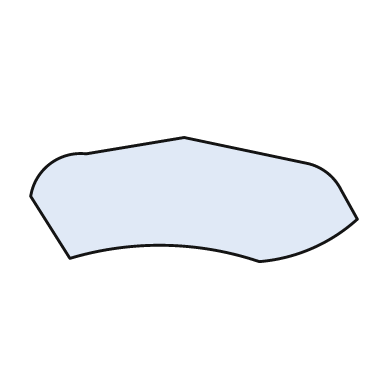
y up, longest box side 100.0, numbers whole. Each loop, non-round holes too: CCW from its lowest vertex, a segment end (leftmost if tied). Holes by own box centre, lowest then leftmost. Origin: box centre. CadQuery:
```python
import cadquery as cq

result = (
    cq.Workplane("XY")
    .moveTo(20.0, -19.0)
    .threePointArc((36.0, -15.0), (50.0, -6.0))
    .lineTo(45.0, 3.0)
    .threePointArc((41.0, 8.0), (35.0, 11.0))
    .lineTo(-3.0, 19.0)
    .lineTo(-33.0, 14.0)
    .threePointArc((-44.0, 11.0), (-50.0, 1.0))
    .lineTo(-38.0, -18.0)
    .threePointArc((-9.0, -14.0), (20.0, -19.0))
    .close()
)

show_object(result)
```